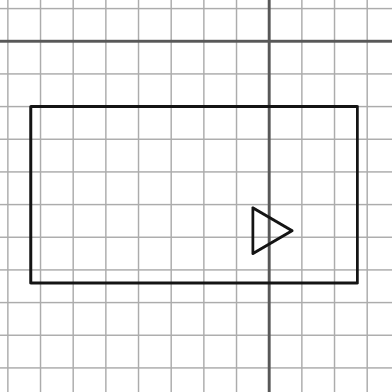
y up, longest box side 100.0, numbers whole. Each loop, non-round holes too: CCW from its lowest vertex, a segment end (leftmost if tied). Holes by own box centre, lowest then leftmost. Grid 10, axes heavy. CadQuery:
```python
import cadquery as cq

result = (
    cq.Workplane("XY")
    .moveTo(-73.0, -74.0)
    .lineTo(27.0, -74.0)
    .lineTo(27.0, -20.0)
    .lineTo(-73.0, -20.0)
    .close()
    .moveTo(-5.0, -65.0)
    .lineTo(7.0, -58.0)
    .lineTo(-5.0, -51.0)
    .close()
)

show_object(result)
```